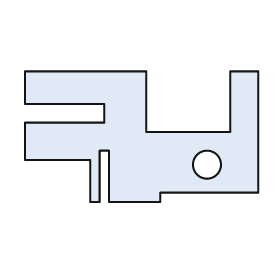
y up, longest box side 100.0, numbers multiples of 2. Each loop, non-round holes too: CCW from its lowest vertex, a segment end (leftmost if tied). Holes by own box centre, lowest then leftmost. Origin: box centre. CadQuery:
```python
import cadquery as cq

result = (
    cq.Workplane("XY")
    .moveTo(-22.0, -28.0)
    .lineTo(-18.0, -28.0)
    .lineTo(-18.0, -6.0)
    .lineTo(-14.0, -6.0)
    .lineTo(-14.0, -28.0)
    .lineTo(8.0, -28.0)
    .lineTo(8.0, -24.0)
    .lineTo(50.0, -24.0)
    .lineTo(50.0, 28.0)
    .lineTo(38.0, 28.0)
    .lineTo(38.0, 2.0)
    .lineTo(2.0, 2.0)
    .lineTo(2.0, 28.0)
    .lineTo(-50.0, 28.0)
    .lineTo(-50.0, 14.0)
    .lineTo(-16.0, 14.0)
    .lineTo(-16.0, 6.0)
    .lineTo(-50.0, 6.0)
    .lineTo(-50.0, -10.0)
    .lineTo(-22.0, -10.0)
    .close()
    .moveTo(28.0, -12.0)
    .circle(6.0)
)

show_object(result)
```